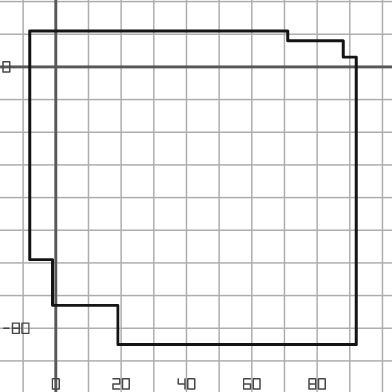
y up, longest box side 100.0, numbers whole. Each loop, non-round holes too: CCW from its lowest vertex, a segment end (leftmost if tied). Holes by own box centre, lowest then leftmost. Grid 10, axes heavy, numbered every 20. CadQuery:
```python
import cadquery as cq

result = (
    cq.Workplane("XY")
    .moveTo(19.0, -85.0)
    .lineTo(92.0, -85.0)
    .lineTo(92.0, 3.0)
    .lineTo(88.0, 3.0)
    .lineTo(88.0, 8.0)
    .lineTo(71.0, 8.0)
    .lineTo(71.0, 11.0)
    .lineTo(-8.0, 11.0)
    .lineTo(-8.0, -59.0)
    .lineTo(-1.0, -59.0)
    .lineTo(-1.0, -73.0)
    .lineTo(19.0, -73.0)
    .close()
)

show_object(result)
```